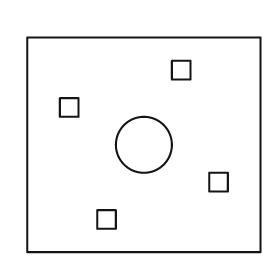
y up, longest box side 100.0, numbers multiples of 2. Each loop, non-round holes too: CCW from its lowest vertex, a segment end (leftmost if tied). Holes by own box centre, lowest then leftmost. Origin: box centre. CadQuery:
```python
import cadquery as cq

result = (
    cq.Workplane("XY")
    .moveTo(-50.0, -46.0)
    .lineTo(50.0, -46.0)
    .lineTo(50.0, 46.0)
    .lineTo(-50.0, 46.0)
    .close()
    .moveTo(-20.0, -36.0)
    .lineTo(-12.0, -36.0)
    .lineTo(-12.0, -28.0)
    .lineTo(-20.0, -28.0)
    .close()
    .moveTo(28.0, -20.0)
    .lineTo(36.0, -20.0)
    .lineTo(36.0, -12.0)
    .lineTo(28.0, -12.0)
    .close()
    .moveTo(0.0, 0.0)
    .circle(12.0)
    .moveTo(-36.0, 12.0)
    .lineTo(-28.0, 12.0)
    .lineTo(-28.0, 20.0)
    .lineTo(-36.0, 20.0)
    .close()
    .moveTo(12.0, 28.0)
    .lineTo(20.0, 28.0)
    .lineTo(20.0, 36.0)
    .lineTo(12.0, 36.0)
    .close()
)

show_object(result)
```